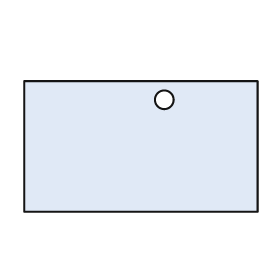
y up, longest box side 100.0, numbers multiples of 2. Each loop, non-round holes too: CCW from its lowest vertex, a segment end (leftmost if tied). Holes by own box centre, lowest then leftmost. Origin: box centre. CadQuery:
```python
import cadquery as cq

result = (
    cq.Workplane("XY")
    .moveTo(-50.0, -28.0)
    .lineTo(50.0, -28.0)
    .lineTo(50.0, 28.0)
    .lineTo(-50.0, 28.0)
    .close()
    .moveTo(10.0, 20.0)
    .circle(4.0)
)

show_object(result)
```